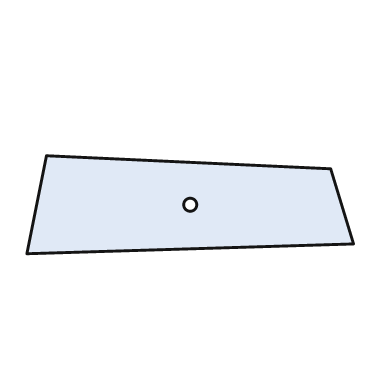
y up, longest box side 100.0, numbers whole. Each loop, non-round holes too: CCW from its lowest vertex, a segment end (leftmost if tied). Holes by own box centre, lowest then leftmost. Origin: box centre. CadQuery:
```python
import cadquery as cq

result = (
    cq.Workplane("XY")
    .moveTo(-50.0, -15.0)
    .lineTo(50.0, -12.0)
    .lineTo(43.0, 11.0)
    .lineTo(-44.0, 15.0)
    .close()
    .moveTo(0.0, 0.0)
    .circle(2.0)
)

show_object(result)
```